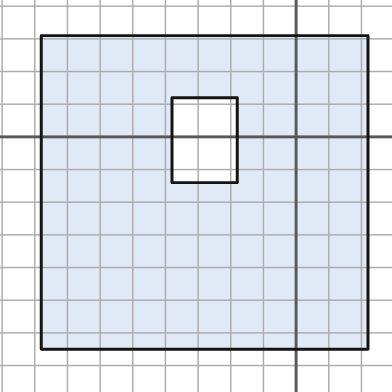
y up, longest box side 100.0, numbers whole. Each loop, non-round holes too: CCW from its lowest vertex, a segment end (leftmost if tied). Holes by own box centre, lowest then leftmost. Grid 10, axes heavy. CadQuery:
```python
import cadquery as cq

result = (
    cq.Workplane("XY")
    .moveTo(-78.0, -65.0)
    .lineTo(22.0, -65.0)
    .lineTo(22.0, 31.0)
    .lineTo(-78.0, 31.0)
    .close()
    .moveTo(-38.0, -14.0)
    .lineTo(-18.0, -14.0)
    .lineTo(-18.0, 12.0)
    .lineTo(-38.0, 12.0)
    .close()
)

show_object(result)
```